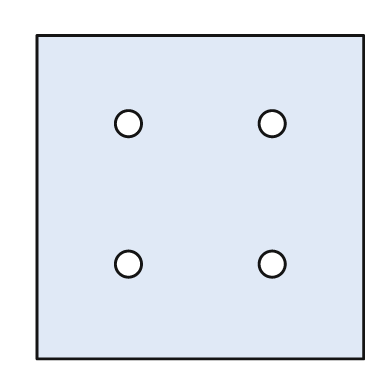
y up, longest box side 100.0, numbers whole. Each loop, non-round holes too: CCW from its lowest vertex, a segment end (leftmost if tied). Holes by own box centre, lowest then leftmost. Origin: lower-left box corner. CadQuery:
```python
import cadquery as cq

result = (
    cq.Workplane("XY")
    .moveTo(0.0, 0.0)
    .lineTo(100.0, 0.0)
    .lineTo(100.0, 99.0)
    .lineTo(0.0, 99.0)
    .close()
    .moveTo(28.0, 29.0)
    .circle(4.0)
    .moveTo(72.0, 29.0)
    .circle(4.0)
    .moveTo(28.0, 72.0)
    .circle(4.0)
    .moveTo(72.0, 72.0)
    .circle(4.0)
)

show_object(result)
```